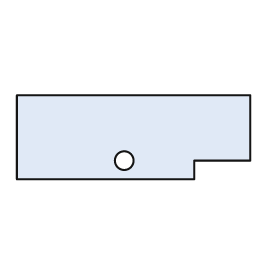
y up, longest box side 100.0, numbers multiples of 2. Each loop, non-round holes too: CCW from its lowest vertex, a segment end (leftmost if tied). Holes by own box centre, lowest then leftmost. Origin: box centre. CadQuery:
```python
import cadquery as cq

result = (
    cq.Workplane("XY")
    .moveTo(-50.0, -18.0)
    .lineTo(26.0, -18.0)
    .lineTo(26.0, -10.0)
    .lineTo(50.0, -10.0)
    .lineTo(50.0, 18.0)
    .lineTo(-50.0, 18.0)
    .close()
    .moveTo(-4.0, -10.0)
    .circle(4.0)
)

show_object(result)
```